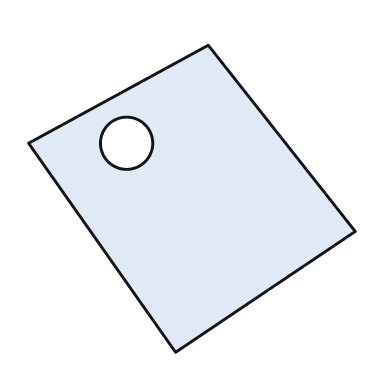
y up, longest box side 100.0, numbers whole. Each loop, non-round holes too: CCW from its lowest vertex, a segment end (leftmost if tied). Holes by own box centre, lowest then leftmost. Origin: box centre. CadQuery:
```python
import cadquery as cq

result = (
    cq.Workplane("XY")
    .moveTo(-5.0, -47.0)
    .lineTo(50.0, -10.0)
    .lineTo(5.0, 47.0)
    .lineTo(-50.0, 17.0)
    .close()
    .moveTo(-20.0, 17.0)
    .circle(8.0)
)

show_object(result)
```